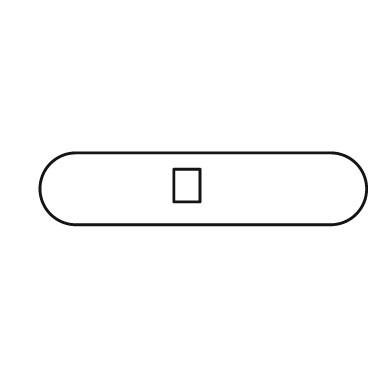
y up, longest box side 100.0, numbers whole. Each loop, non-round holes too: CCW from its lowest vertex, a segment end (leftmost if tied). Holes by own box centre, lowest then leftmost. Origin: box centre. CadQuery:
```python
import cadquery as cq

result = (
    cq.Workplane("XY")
    .moveTo(-39.0, -11.0)
    .lineTo(39.0, -11.0)
    .threePointArc((50.0, 0.0), (39.0, 11.0))
    .lineTo(-39.0, 11.0)
    .threePointArc((-50.0, 0.0), (-39.0, -11.0))
    .close()
    .moveTo(-9.0, -4.0)
    .lineTo(-1.0, -4.0)
    .lineTo(-1.0, 6.0)
    .lineTo(-9.0, 6.0)
    .close()
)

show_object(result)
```